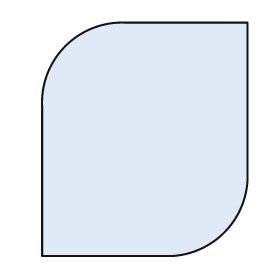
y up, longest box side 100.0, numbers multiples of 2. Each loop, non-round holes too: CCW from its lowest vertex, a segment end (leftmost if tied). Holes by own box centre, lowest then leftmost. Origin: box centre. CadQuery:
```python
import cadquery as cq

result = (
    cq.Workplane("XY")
    .moveTo(-44.0, -50.0)
    .lineTo(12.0, -50.0)
    .threePointArc((34.0, -40.0), (44.0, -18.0))
    .lineTo(44.0, 50.0)
    .lineTo(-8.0, 50.0)
    .threePointArc((-34.0, 40.0), (-44.0, 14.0))
    .close()
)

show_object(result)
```